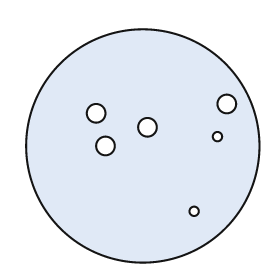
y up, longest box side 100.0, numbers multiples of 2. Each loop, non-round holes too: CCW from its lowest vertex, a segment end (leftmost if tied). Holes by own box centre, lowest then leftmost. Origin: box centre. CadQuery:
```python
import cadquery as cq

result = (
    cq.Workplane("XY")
    .moveTo(0.0, 0.0)
    .circle(50.0)
    .moveTo(22.0, -28.0)
    .circle(2.0)
    .moveTo(-16.0, 0.0)
    .circle(4.0)
    .moveTo(32.0, 4.0)
    .circle(2.0)
    .moveTo(2.0, 8.0)
    .circle(4.0)
    .moveTo(-20.0, 14.0)
    .circle(4.0)
    .moveTo(36.0, 18.0)
    .circle(4.0)
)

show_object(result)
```